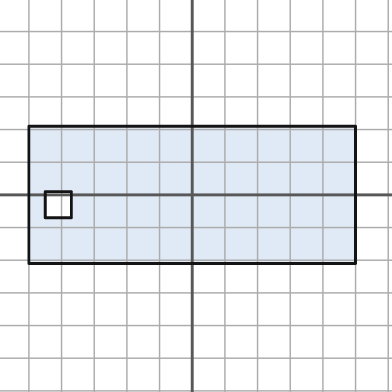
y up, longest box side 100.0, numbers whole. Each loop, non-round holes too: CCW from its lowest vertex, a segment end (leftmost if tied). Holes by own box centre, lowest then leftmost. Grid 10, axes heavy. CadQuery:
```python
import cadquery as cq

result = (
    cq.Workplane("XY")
    .moveTo(-50.0, -21.0)
    .lineTo(50.0, -21.0)
    .lineTo(50.0, 21.0)
    .lineTo(-50.0, 21.0)
    .close()
    .moveTo(-45.0, -7.0)
    .lineTo(-37.0, -7.0)
    .lineTo(-37.0, 1.0)
    .lineTo(-45.0, 1.0)
    .close()
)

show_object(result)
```